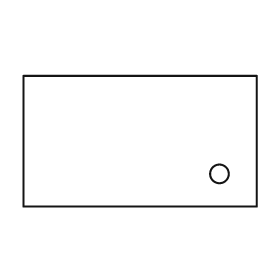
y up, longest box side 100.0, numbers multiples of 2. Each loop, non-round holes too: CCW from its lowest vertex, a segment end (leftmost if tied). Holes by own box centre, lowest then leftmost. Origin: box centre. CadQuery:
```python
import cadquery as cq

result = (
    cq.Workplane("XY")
    .moveTo(-50.0, -28.0)
    .lineTo(50.0, -28.0)
    .lineTo(50.0, 28.0)
    .lineTo(-50.0, 28.0)
    .close()
    .moveTo(34.0, -14.0)
    .circle(4.0)
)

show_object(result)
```